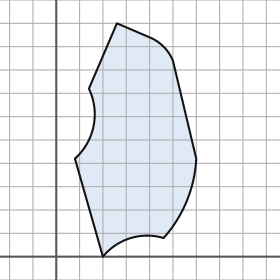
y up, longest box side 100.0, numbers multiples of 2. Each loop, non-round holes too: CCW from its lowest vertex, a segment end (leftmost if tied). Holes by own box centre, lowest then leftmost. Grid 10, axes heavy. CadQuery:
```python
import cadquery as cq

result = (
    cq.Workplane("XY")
    .moveTo(20.0, 0.0)
    .threePointArc((32.0, 8.0), (46.0, 8.0))
    .threePointArc((56.0, 24.0), (60.0, 42.0))
    .lineTo(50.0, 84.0)
    .threePointArc((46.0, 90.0), (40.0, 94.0))
    .lineTo(26.0, 100.0)
    .lineTo(14.0, 72.0)
    .threePointArc((16.0, 56.0), (8.0, 42.0))
    .close()
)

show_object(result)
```